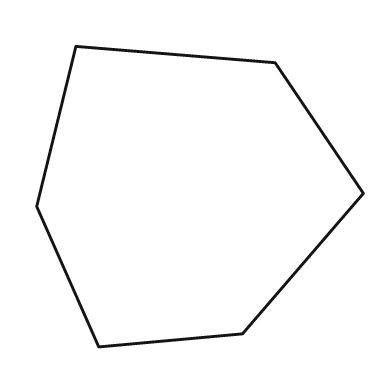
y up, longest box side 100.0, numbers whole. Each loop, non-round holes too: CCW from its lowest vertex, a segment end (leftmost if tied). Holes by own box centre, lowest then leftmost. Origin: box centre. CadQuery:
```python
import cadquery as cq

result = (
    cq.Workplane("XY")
    .moveTo(-31.0, -46.0)
    .lineTo(13.0, -42.0)
    .lineTo(50.0, 1.0)
    .lineTo(23.0, 41.0)
    .lineTo(-38.0, 46.0)
    .lineTo(-50.0, -3.0)
    .close()
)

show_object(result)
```